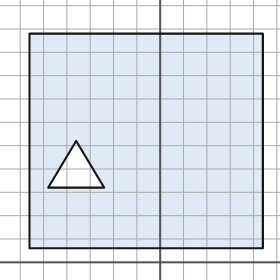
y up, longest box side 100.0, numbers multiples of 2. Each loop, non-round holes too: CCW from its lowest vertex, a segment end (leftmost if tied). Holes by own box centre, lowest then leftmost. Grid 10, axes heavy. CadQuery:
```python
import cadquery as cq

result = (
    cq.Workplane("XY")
    .moveTo(-56.0, 6.0)
    .lineTo(44.0, 6.0)
    .lineTo(44.0, 98.0)
    .lineTo(-56.0, 98.0)
    .close()
    .moveTo(-48.0, 32.0)
    .lineTo(-24.0, 32.0)
    .lineTo(-36.0, 52.0)
    .close()
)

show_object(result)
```